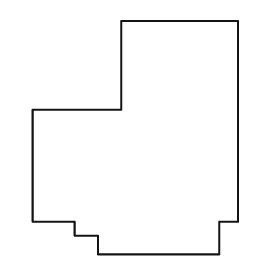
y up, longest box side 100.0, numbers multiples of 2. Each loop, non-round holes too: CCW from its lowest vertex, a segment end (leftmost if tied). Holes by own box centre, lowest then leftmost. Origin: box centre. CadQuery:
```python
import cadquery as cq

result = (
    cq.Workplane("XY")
    .moveTo(-16.0, -50.0)
    .lineTo(36.0, -50.0)
    .lineTo(36.0, -36.0)
    .lineTo(44.0, -36.0)
    .lineTo(44.0, 50.0)
    .lineTo(-6.0, 50.0)
    .lineTo(-6.0, 12.0)
    .lineTo(-44.0, 12.0)
    .lineTo(-44.0, -36.0)
    .lineTo(-26.0, -36.0)
    .lineTo(-26.0, -42.0)
    .lineTo(-16.0, -42.0)
    .close()
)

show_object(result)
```